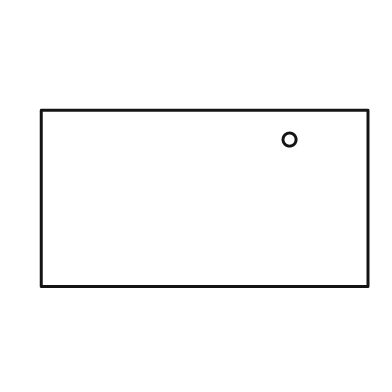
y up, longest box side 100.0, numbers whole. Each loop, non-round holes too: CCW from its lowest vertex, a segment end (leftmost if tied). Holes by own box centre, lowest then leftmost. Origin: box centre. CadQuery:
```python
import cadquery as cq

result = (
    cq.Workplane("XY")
    .moveTo(-50.0, -27.0)
    .lineTo(50.0, -27.0)
    .lineTo(50.0, 27.0)
    .lineTo(-50.0, 27.0)
    .close()
    .moveTo(26.0, 18.0)
    .circle(2.0)
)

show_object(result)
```